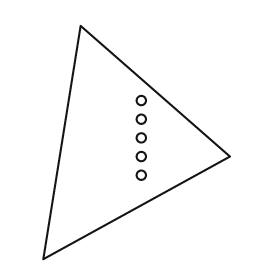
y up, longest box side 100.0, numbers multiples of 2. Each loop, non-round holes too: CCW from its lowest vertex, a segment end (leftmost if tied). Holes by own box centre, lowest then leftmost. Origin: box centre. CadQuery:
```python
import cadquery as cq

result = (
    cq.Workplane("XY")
    .moveTo(-40.0, -50.0)
    .lineTo(40.0, -6.0)
    .lineTo(-24.0, 50.0)
    .close()
    .moveTo(2.0, -14.0)
    .circle(2.0)
    .moveTo(2.0, -6.0)
    .circle(2.0)
    .moveTo(2.0, 2.0)
    .circle(2.0)
    .moveTo(2.0, 10.0)
    .circle(2.0)
    .moveTo(2.0, 18.0)
    .circle(2.0)
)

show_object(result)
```